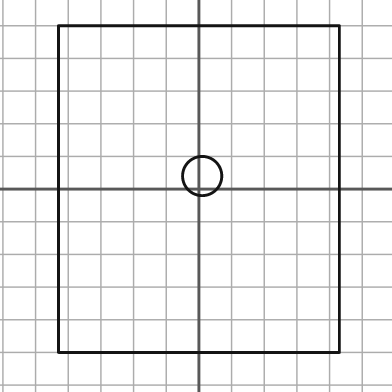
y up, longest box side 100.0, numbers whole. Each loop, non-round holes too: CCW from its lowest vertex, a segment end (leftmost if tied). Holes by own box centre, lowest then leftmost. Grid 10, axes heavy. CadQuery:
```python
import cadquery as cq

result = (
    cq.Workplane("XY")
    .moveTo(-43.0, -50.0)
    .lineTo(43.0, -50.0)
    .lineTo(43.0, 50.0)
    .lineTo(-43.0, 50.0)
    .close()
    .moveTo(1.0, 4.0)
    .circle(6.0)
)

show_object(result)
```